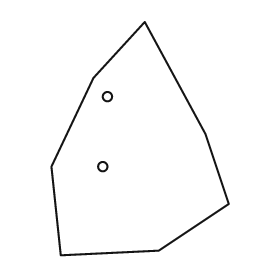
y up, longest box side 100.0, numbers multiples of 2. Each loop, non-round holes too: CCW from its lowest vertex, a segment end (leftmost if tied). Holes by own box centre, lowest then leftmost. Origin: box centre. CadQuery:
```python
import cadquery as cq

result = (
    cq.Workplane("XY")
    .moveTo(-34.0, -50.0)
    .lineTo(8.0, -48.0)
    .lineTo(38.0, -28.0)
    .lineTo(28.0, 2.0)
    .lineTo(2.0, 50.0)
    .lineTo(-20.0, 26.0)
    .lineTo(-38.0, -12.0)
    .close()
    .moveTo(-16.0, -12.0)
    .circle(2.0)
    .moveTo(-14.0, 18.0)
    .circle(2.0)
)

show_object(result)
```